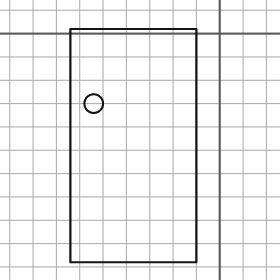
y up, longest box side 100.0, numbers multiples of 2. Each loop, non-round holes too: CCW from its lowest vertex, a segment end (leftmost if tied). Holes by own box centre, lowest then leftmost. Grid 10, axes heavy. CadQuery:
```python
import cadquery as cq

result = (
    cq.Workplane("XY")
    .moveTo(-64.0, -98.0)
    .lineTo(-10.0, -98.0)
    .lineTo(-10.0, 2.0)
    .lineTo(-64.0, 2.0)
    .close()
    .moveTo(-54.0, -30.0)
    .circle(4.0)
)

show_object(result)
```